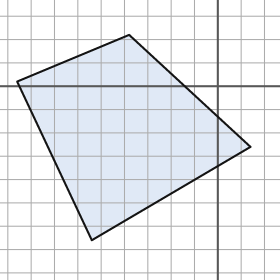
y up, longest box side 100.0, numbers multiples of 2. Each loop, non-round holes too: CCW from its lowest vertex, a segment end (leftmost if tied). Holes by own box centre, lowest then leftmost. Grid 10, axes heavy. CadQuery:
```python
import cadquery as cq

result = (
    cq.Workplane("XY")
    .moveTo(-54.0, -66.0)
    .lineTo(14.0, -26.0)
    .lineTo(-38.0, 22.0)
    .lineTo(-86.0, 2.0)
    .close()
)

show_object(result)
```